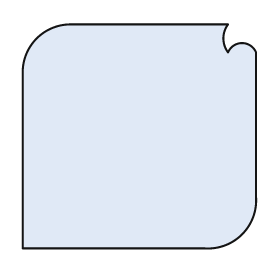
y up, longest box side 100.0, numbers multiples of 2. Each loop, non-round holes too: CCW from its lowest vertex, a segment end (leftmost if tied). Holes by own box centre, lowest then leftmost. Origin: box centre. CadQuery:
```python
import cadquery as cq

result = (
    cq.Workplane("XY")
    .moveTo(-50.0, -48.0)
    .lineTo(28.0, -48.0)
    .threePointArc((44.0, -42.0), (50.0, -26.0))
    .lineTo(50.0, 36.0)
    .threePointArc((44.0, 40.0), (38.0, 36.0))
    .threePointArc((36.0, 42.0), (38.0, 48.0))
    .lineTo(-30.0, 48.0)
    .threePointArc((-44.0, 42.0), (-50.0, 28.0))
    .close()
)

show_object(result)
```